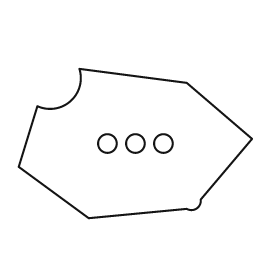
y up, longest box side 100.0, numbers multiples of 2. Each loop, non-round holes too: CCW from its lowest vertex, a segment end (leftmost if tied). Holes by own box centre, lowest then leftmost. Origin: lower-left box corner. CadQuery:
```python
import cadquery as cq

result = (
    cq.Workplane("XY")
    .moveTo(30.0, 0.0)
    .lineTo(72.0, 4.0)
    .threePointArc((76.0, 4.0), (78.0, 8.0))
    .lineTo(100.0, 34.0)
    .lineTo(72.0, 58.0)
    .lineTo(26.0, 64.0)
    .threePointArc((22.0, 50.0), (8.0, 48.0))
    .lineTo(0.0, 22.0)
    .close()
    .moveTo(38.0, 32.0)
    .circle(4.0)
    .moveTo(50.0, 32.0)
    .circle(4.0)
    .moveTo(62.0, 32.0)
    .circle(4.0)
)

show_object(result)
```